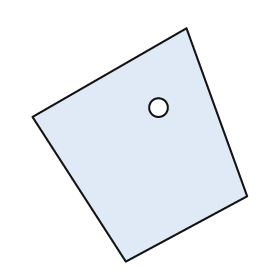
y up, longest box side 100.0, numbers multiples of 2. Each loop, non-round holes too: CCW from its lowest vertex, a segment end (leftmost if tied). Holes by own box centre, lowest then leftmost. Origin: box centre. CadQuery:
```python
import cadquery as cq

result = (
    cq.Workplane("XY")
    .moveTo(-6.0, -50.0)
    .lineTo(46.0, -22.0)
    .lineTo(20.0, 50.0)
    .lineTo(-46.0, 12.0)
    .close()
    .moveTo(8.0, 16.0)
    .circle(4.0)
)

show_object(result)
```